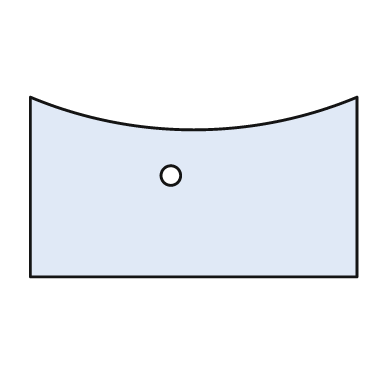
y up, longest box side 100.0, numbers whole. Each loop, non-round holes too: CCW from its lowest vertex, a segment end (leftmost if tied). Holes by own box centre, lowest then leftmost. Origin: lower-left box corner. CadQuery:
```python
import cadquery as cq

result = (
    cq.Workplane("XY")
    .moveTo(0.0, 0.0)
    .lineTo(100.0, 0.0)
    .lineTo(100.0, 55.0)
    .threePointArc((50.0, 45.0), (0.0, 55.0))
    .close()
    .moveTo(43.0, 31.0)
    .circle(3.0)
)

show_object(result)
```